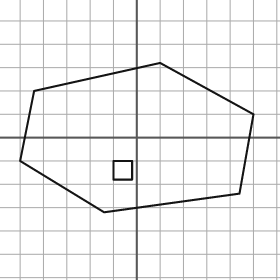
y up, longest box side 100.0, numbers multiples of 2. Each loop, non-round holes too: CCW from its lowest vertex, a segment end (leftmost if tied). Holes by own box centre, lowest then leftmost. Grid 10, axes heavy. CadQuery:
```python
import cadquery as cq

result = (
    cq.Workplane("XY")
    .moveTo(-14.0, -32.0)
    .lineTo(44.0, -24.0)
    .lineTo(50.0, 10.0)
    .lineTo(10.0, 32.0)
    .lineTo(-44.0, 20.0)
    .lineTo(-50.0, -10.0)
    .close()
    .moveTo(-10.0, -18.0)
    .lineTo(-2.0, -18.0)
    .lineTo(-2.0, -10.0)
    .lineTo(-10.0, -10.0)
    .close()
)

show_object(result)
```